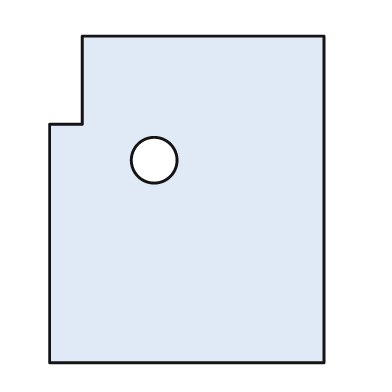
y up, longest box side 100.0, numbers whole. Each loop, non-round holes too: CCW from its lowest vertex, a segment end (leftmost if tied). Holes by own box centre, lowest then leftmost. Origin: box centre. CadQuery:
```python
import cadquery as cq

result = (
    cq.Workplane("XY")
    .moveTo(-42.0, -50.0)
    .lineTo(42.0, -50.0)
    .lineTo(42.0, 50.0)
    .lineTo(-32.0, 50.0)
    .lineTo(-32.0, 23.0)
    .lineTo(-42.0, 23.0)
    .close()
    .moveTo(-10.0, 12.0)
    .circle(7.0)
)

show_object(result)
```